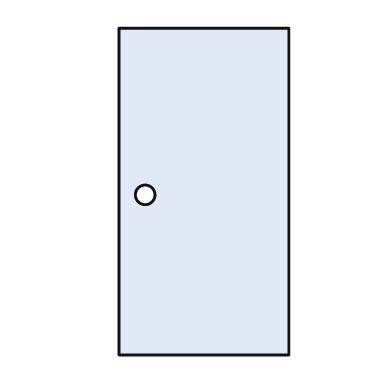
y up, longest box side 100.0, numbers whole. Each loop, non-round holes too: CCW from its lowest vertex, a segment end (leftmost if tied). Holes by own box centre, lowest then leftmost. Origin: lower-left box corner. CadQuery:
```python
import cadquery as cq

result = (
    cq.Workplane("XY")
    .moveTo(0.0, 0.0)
    .lineTo(52.0, 0.0)
    .lineTo(52.0, 100.0)
    .lineTo(0.0, 100.0)
    .close()
    .moveTo(8.0, 49.0)
    .circle(3.0)
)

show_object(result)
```